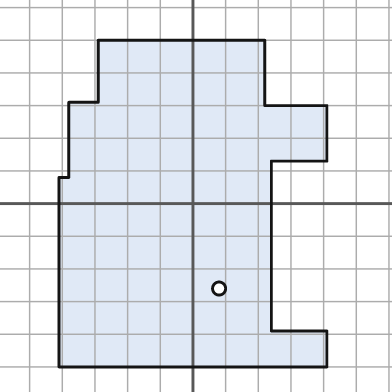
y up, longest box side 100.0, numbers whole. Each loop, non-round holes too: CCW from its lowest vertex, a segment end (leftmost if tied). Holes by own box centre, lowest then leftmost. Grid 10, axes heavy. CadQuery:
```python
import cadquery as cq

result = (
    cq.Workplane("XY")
    .moveTo(-41.0, -50.0)
    .lineTo(41.0, -50.0)
    .lineTo(41.0, -39.0)
    .lineTo(24.0, -39.0)
    .lineTo(24.0, 13.0)
    .lineTo(41.0, 13.0)
    .lineTo(41.0, 30.0)
    .lineTo(22.0, 30.0)
    .lineTo(22.0, 50.0)
    .lineTo(-29.0, 50.0)
    .lineTo(-29.0, 31.0)
    .lineTo(-38.0, 31.0)
    .lineTo(-38.0, 8.0)
    .lineTo(-41.0, 8.0)
    .close()
    .moveTo(8.0, -26.0)
    .circle(2.0)
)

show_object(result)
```